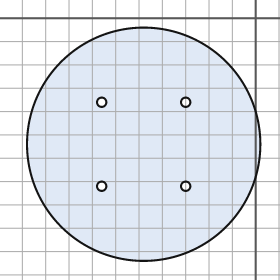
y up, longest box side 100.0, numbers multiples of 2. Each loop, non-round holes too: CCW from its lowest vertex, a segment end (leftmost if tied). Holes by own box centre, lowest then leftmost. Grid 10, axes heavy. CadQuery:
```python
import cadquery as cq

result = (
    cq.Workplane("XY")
    .moveTo(-48.0, -54.0)
    .circle(50.0)
    .moveTo(-66.0, -72.0)
    .circle(2.0)
    .moveTo(-30.0, -72.0)
    .circle(2.0)
    .moveTo(-66.0, -36.0)
    .circle(2.0)
    .moveTo(-30.0, -36.0)
    .circle(2.0)
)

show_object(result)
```